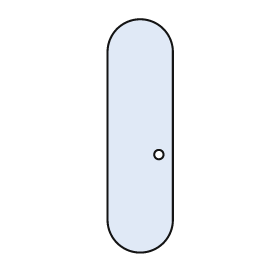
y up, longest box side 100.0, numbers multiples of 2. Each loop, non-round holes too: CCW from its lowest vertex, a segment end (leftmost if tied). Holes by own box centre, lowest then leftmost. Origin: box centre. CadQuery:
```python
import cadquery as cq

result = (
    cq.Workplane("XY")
    .moveTo(-14.0, -36.0)
    .threePointArc((0.0, -50.0), (14.0, -36.0))
    .lineTo(14.0, 36.0)
    .threePointArc((0.0, 50.0), (-14.0, 36.0))
    .close()
    .moveTo(8.0, -8.0)
    .circle(2.0)
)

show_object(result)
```